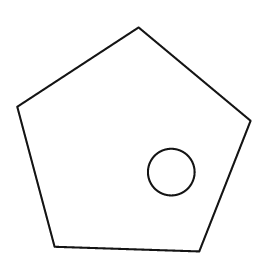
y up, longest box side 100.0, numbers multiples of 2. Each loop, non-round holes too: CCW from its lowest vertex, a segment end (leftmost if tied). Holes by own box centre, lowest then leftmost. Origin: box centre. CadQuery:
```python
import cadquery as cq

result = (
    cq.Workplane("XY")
    .moveTo(28.0, -48.0)
    .lineTo(50.0, 8.0)
    .lineTo(2.0, 48.0)
    .lineTo(-50.0, 14.0)
    .lineTo(-34.0, -46.0)
    .close()
    .moveTo(16.0, -14.0)
    .circle(10.0)
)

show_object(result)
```